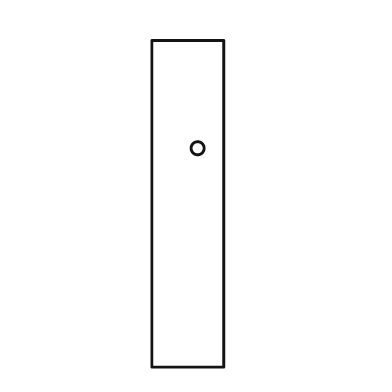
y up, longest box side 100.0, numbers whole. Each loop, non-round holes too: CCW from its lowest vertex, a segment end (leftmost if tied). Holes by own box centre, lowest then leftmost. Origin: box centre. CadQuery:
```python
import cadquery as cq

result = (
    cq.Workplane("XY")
    .moveTo(-11.0, -50.0)
    .lineTo(11.0, -50.0)
    .lineTo(11.0, 50.0)
    .lineTo(-11.0, 50.0)
    .close()
    .moveTo(3.0, 17.0)
    .circle(2.0)
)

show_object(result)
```